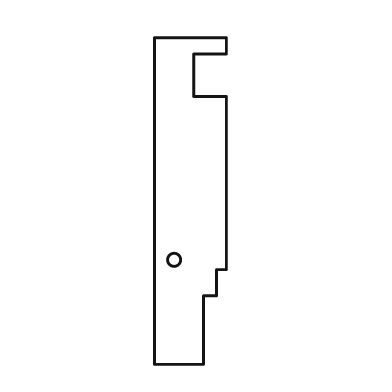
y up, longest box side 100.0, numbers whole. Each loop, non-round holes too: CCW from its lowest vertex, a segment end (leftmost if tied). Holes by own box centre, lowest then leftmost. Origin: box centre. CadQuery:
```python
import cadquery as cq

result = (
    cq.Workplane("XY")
    .moveTo(-11.0, -50.0)
    .lineTo(4.0, -50.0)
    .lineTo(4.0, -29.0)
    .lineTo(8.0, -29.0)
    .lineTo(8.0, -21.0)
    .lineTo(11.0, -21.0)
    .lineTo(11.0, 32.0)
    .lineTo(1.0, 32.0)
    .lineTo(1.0, 45.0)
    .lineTo(11.0, 45.0)
    .lineTo(11.0, 50.0)
    .lineTo(-11.0, 50.0)
    .close()
    .moveTo(-5.0, -18.0)
    .circle(2.0)
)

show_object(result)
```